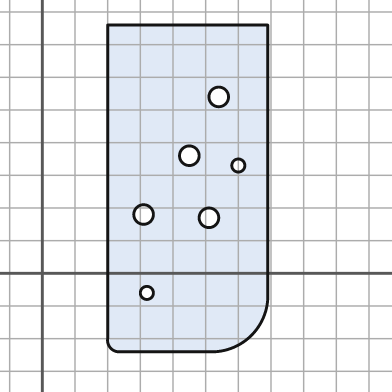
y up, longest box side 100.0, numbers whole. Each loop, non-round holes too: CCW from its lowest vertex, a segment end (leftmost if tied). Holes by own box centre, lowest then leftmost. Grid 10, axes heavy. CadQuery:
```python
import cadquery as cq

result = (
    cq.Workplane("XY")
    .moveTo(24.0, -24.0)
    .lineTo(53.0, -24.0)
    .threePointArc((64.0, -19.0), (69.0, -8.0))
    .lineTo(69.0, 76.0)
    .lineTo(20.0, 76.0)
    .lineTo(20.0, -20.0)
    .threePointArc((21.0, -23.0), (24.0, -24.0))
    .close()
    .moveTo(32.0, -6.0)
    .circle(2.0)
    .moveTo(51.0, 17.0)
    .circle(3.0)
    .moveTo(31.0, 18.0)
    .circle(3.0)
    .moveTo(60.0, 33.0)
    .circle(2.0)
    .moveTo(45.0, 36.0)
    .circle(3.0)
    .moveTo(54.0, 54.0)
    .circle(3.0)
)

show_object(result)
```